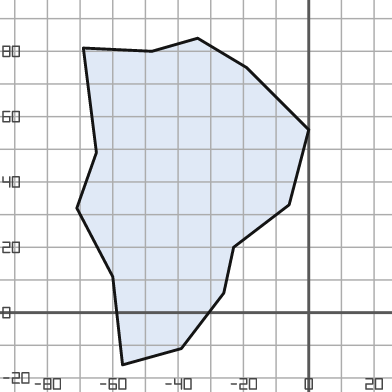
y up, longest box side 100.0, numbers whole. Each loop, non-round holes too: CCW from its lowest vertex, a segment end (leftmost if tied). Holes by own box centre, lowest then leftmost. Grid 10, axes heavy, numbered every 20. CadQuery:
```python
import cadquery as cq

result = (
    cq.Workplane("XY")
    .moveTo(-57.0, -16.0)
    .lineTo(-39.0, -11.0)
    .lineTo(-26.0, 6.0)
    .lineTo(-23.0, 20.0)
    .lineTo(-6.0, 33.0)
    .lineTo(0.0, 56.0)
    .lineTo(-19.0, 75.0)
    .lineTo(-34.0, 84.0)
    .lineTo(-48.0, 80.0)
    .lineTo(-69.0, 81.0)
    .lineTo(-65.0, 49.0)
    .lineTo(-71.0, 32.0)
    .lineTo(-60.0, 11.0)
    .close()
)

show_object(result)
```